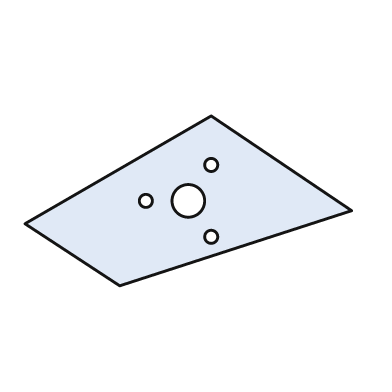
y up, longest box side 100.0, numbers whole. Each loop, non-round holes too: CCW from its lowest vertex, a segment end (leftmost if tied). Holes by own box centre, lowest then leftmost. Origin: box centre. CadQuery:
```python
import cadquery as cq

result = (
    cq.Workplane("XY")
    .moveTo(-21.0, -26.0)
    .lineTo(50.0, -3.0)
    .lineTo(7.0, 26.0)
    .lineTo(-50.0, -7.0)
    .close()
    .moveTo(7.0, -11.0)
    .circle(2.0)
    .moveTo(-13.0, 0.0)
    .circle(2.0)
    .moveTo(0.0, 0.0)
    .circle(5.0)
    .moveTo(7.0, 11.0)
    .circle(2.0)
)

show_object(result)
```